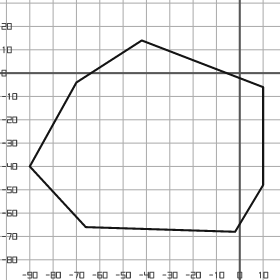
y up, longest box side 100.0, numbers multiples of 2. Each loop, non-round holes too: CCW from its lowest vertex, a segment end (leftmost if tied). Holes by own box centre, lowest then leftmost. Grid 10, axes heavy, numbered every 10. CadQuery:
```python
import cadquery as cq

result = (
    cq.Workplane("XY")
    .moveTo(-2.0, -68.0)
    .lineTo(10.0, -48.0)
    .lineTo(10.0, -6.0)
    .lineTo(-42.0, 14.0)
    .lineTo(-70.0, -4.0)
    .lineTo(-90.0, -40.0)
    .lineTo(-66.0, -66.0)
    .close()
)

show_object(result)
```